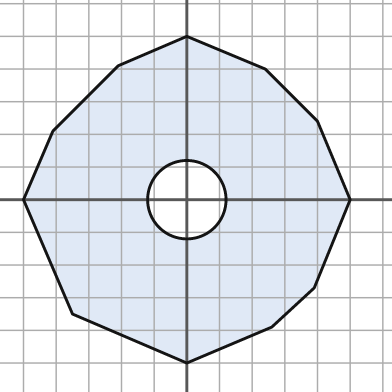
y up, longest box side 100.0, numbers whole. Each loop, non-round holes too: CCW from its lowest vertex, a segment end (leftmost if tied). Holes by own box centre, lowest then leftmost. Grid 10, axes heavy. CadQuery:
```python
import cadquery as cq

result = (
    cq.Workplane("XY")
    .moveTo(0.0, -50.0)
    .lineTo(26.0, -39.0)
    .lineTo(39.0, -27.0)
    .lineTo(50.0, 0.0)
    .lineTo(40.0, 24.0)
    .lineTo(24.0, 40.0)
    .lineTo(0.0, 50.0)
    .lineTo(-21.0, 41.0)
    .lineTo(-41.0, 21.0)
    .lineTo(-50.0, 0.0)
    .lineTo(-35.0, -35.0)
    .close()
    .moveTo(0.0, 0.0)
    .circle(12.0)
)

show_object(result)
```